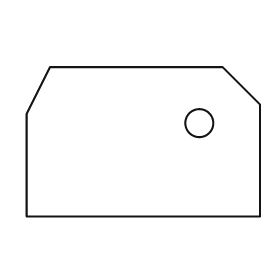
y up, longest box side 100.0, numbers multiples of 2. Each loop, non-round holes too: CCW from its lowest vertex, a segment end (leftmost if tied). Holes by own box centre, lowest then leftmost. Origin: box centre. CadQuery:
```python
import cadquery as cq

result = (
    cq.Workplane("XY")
    .moveTo(-50.0, -32.0)
    .lineTo(50.0, -32.0)
    .lineTo(50.0, 16.0)
    .lineTo(34.0, 32.0)
    .lineTo(-40.0, 32.0)
    .lineTo(-50.0, 12.0)
    .close()
    .moveTo(24.0, 8.0)
    .circle(6.0)
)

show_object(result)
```